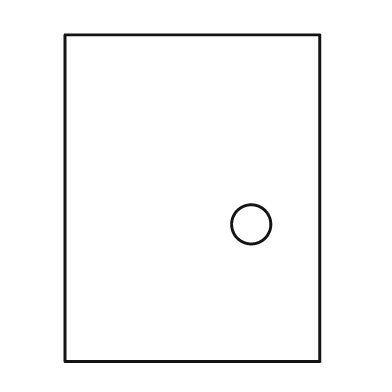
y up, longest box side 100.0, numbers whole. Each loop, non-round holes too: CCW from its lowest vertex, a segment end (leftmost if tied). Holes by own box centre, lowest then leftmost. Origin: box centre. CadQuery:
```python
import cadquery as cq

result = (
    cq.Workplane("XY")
    .moveTo(-39.0, -50.0)
    .lineTo(39.0, -50.0)
    .lineTo(39.0, 50.0)
    .lineTo(-39.0, 50.0)
    .close()
    .moveTo(18.0, -8.0)
    .circle(6.0)
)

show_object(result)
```